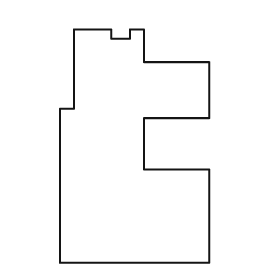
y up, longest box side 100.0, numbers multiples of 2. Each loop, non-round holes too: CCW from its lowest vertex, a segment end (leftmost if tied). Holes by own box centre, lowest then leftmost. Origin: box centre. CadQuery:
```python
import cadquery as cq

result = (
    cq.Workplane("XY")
    .moveTo(-32.0, -50.0)
    .lineTo(32.0, -50.0)
    .lineTo(32.0, -10.0)
    .lineTo(4.0, -10.0)
    .lineTo(4.0, 12.0)
    .lineTo(32.0, 12.0)
    .lineTo(32.0, 36.0)
    .lineTo(4.0, 36.0)
    .lineTo(4.0, 50.0)
    .lineTo(-2.0, 50.0)
    .lineTo(-2.0, 46.0)
    .lineTo(-10.0, 46.0)
    .lineTo(-10.0, 50.0)
    .lineTo(-26.0, 50.0)
    .lineTo(-26.0, 16.0)
    .lineTo(-32.0, 16.0)
    .close()
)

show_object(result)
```